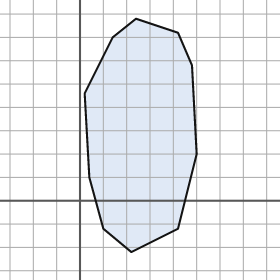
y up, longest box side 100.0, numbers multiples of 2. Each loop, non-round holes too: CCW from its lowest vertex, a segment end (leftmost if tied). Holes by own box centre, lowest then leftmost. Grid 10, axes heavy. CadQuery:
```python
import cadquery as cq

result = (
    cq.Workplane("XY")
    .moveTo(22.0, -22.0)
    .lineTo(42.0, -12.0)
    .lineTo(50.0, 20.0)
    .lineTo(48.0, 58.0)
    .lineTo(42.0, 72.0)
    .lineTo(24.0, 78.0)
    .lineTo(14.0, 70.0)
    .lineTo(2.0, 46.0)
    .lineTo(4.0, 10.0)
    .lineTo(10.0, -12.0)
    .close()
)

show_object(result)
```